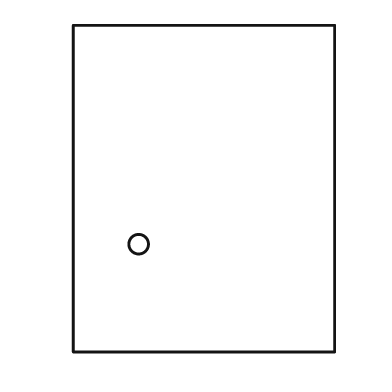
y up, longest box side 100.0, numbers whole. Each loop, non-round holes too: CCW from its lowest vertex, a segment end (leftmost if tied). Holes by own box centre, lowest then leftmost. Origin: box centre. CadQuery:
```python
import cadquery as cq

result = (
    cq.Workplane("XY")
    .moveTo(-40.0, -50.0)
    .lineTo(40.0, -50.0)
    .lineTo(40.0, 50.0)
    .lineTo(-40.0, 50.0)
    .close()
    .moveTo(-20.0, -17.0)
    .circle(3.0)
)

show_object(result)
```